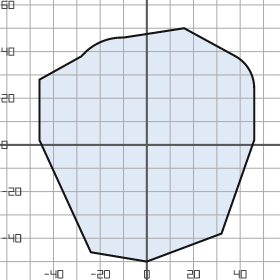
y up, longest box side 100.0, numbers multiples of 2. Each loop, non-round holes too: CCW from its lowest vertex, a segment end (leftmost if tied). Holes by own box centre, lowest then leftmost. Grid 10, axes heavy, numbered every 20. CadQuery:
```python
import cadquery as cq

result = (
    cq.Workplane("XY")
    .moveTo(0.0, -50.0)
    .lineTo(32.0, -38.0)
    .lineTo(46.0, 2.0)
    .lineTo(46.0, 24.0)
    .threePointArc((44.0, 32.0), (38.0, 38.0))
    .lineTo(16.0, 50.0)
    .lineTo(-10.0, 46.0)
    .threePointArc((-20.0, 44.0), (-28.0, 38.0))
    .lineTo(-46.0, 28.0)
    .lineTo(-46.0, 2.0)
    .lineTo(-24.0, -46.0)
    .close()
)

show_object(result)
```